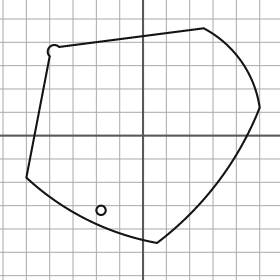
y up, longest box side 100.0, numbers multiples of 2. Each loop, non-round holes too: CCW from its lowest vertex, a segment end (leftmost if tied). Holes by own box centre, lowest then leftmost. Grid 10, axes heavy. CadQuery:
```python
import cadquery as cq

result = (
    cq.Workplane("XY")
    .moveTo(6.0, -46.0)
    .threePointArc((32.0, -20.0), (50.0, 12.0))
    .threePointArc((42.0, 32.0), (26.0, 46.0))
    .lineTo(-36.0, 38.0)
    .threePointArc((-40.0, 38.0), (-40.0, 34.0))
    .lineTo(-50.0, -18.0)
    .threePointArc((-24.0, -36.0), (6.0, -46.0))
    .close()
    .moveTo(-18.0, -32.0)
    .circle(2.0)
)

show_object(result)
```